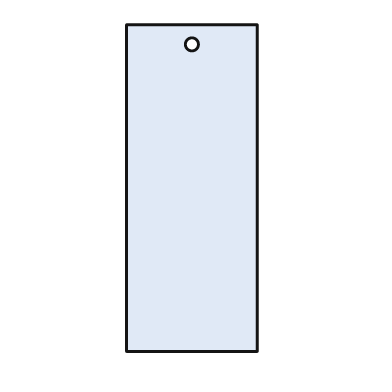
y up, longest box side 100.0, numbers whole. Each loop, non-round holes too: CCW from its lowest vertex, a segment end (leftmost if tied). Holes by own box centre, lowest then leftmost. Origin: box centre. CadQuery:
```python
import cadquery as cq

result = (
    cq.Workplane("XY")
    .moveTo(-20.0, -50.0)
    .lineTo(20.0, -50.0)
    .lineTo(20.0, 50.0)
    .lineTo(-20.0, 50.0)
    .close()
    .moveTo(0.0, 44.0)
    .circle(2.0)
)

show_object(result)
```